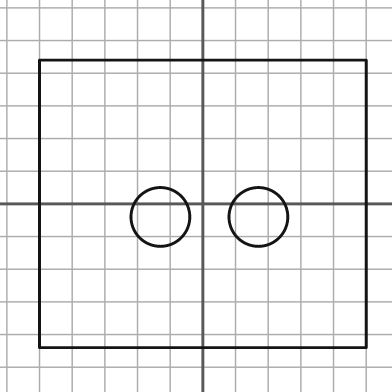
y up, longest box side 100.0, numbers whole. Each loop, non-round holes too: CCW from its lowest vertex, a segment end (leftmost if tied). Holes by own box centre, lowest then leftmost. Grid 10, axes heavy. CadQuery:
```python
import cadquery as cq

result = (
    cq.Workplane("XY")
    .moveTo(-50.0, -44.0)
    .lineTo(50.0, -44.0)
    .lineTo(50.0, 44.0)
    .lineTo(-50.0, 44.0)
    .close()
    .moveTo(-13.0, -4.0)
    .circle(9.0)
    .moveTo(17.0, -4.0)
    .circle(9.0)
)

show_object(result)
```